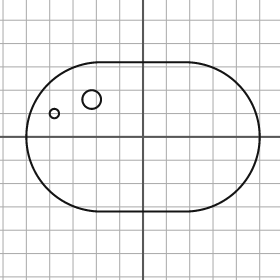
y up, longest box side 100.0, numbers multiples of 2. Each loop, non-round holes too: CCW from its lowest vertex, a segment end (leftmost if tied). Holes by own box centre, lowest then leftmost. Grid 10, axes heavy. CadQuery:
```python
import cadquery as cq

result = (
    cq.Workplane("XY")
    .moveTo(-18.0, -32.0)
    .lineTo(18.0, -32.0)
    .threePointArc((50.0, 0.0), (18.0, 32.0))
    .lineTo(-18.0, 32.0)
    .threePointArc((-50.0, 0.0), (-18.0, -32.0))
    .close()
    .moveTo(-38.0, 10.0)
    .circle(2.0)
    .moveTo(-22.0, 16.0)
    .circle(4.0)
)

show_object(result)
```